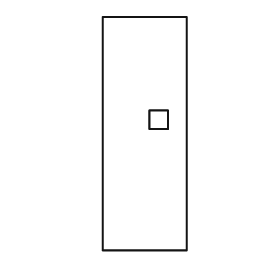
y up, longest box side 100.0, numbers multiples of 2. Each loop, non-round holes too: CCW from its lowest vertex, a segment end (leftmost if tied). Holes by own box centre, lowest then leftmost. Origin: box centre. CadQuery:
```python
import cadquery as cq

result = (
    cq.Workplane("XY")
    .moveTo(-18.0, -50.0)
    .lineTo(18.0, -50.0)
    .lineTo(18.0, 50.0)
    .lineTo(-18.0, 50.0)
    .close()
    .moveTo(2.0, 2.0)
    .lineTo(10.0, 2.0)
    .lineTo(10.0, 10.0)
    .lineTo(2.0, 10.0)
    .close()
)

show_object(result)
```